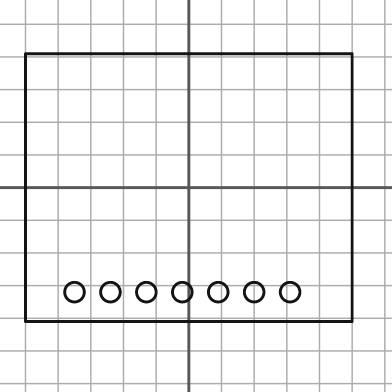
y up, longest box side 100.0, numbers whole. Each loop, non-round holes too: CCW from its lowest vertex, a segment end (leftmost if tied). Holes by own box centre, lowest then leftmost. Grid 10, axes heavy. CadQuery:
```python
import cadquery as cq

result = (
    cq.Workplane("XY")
    .moveTo(-50.0, -41.0)
    .lineTo(50.0, -41.0)
    .lineTo(50.0, 41.0)
    .lineTo(-50.0, 41.0)
    .close()
    .moveTo(-35.0, -32.0)
    .circle(3.0)
    .moveTo(-24.0, -32.0)
    .circle(3.0)
    .moveTo(-13.0, -32.0)
    .circle(3.0)
    .moveTo(-2.0, -32.0)
    .circle(3.0)
    .moveTo(9.0, -32.0)
    .circle(3.0)
    .moveTo(20.0, -32.0)
    .circle(3.0)
    .moveTo(31.0, -32.0)
    .circle(3.0)
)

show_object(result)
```